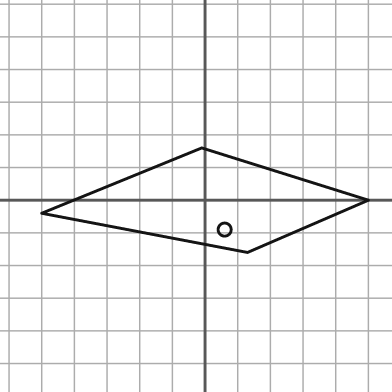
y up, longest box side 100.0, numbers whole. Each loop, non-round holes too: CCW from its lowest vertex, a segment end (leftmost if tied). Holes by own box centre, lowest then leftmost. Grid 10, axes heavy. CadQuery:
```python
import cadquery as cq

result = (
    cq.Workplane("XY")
    .moveTo(13.0, -16.0)
    .lineTo(50.0, 0.0)
    .lineTo(-1.0, 16.0)
    .lineTo(-50.0, -4.0)
    .close()
    .moveTo(6.0, -9.0)
    .circle(2.0)
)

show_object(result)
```